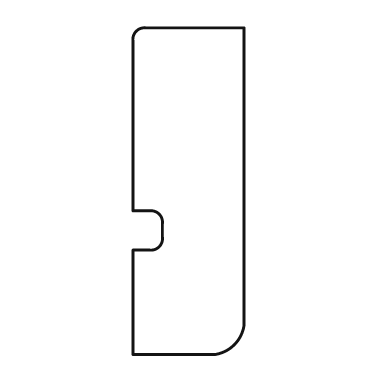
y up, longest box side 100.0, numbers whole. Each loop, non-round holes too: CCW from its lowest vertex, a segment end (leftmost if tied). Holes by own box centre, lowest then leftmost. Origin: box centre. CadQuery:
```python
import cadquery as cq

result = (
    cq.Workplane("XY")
    .moveTo(-17.0, -50.0)
    .lineTo(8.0, -50.0)
    .threePointArc((14.0, -47.0), (17.0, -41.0))
    .lineTo(17.0, 50.0)
    .lineTo(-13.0, 50.0)
    .threePointArc((-16.0, 49.0), (-17.0, 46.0))
    .lineTo(-17.0, -6.0)
    .lineTo(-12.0, -6.0)
    .threePointArc((-9.0, -7.0), (-8.0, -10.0))
    .lineTo(-8.0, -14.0)
    .threePointArc((-9.0, -17.0), (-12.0, -18.0))
    .lineTo(-17.0, -18.0)
    .close()
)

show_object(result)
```